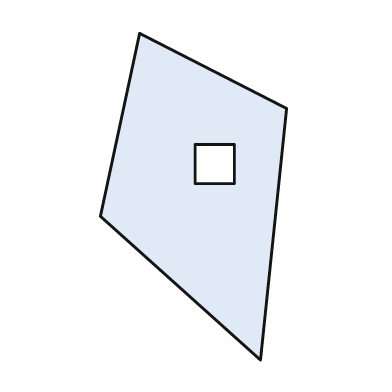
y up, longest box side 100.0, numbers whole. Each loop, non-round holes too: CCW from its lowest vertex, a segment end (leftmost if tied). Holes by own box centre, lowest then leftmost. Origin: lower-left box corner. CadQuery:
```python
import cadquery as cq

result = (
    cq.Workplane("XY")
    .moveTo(49.0, 0.0)
    .lineTo(57.0, 77.0)
    .lineTo(12.0, 100.0)
    .lineTo(0.0, 44.0)
    .close()
    .moveTo(29.0, 54.0)
    .lineTo(41.0, 54.0)
    .lineTo(41.0, 66.0)
    .lineTo(29.0, 66.0)
    .close()
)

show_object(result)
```